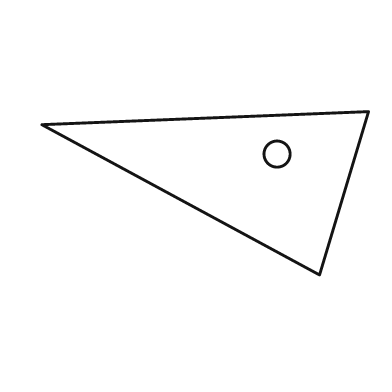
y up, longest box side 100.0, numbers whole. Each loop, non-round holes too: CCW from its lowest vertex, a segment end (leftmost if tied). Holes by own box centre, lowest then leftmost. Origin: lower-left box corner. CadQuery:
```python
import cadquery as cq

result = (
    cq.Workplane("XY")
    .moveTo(85.0, 0.0)
    .lineTo(100.0, 50.0)
    .lineTo(0.0, 46.0)
    .close()
    .moveTo(72.0, 37.0)
    .circle(4.0)
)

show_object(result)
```